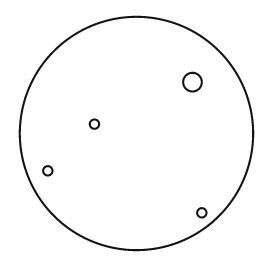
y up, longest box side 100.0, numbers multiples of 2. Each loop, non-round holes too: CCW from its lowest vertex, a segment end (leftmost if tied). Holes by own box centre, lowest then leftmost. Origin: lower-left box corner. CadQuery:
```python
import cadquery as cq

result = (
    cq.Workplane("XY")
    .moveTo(50.0, 50.0)
    .circle(50.0)
    .moveTo(78.0, 16.0)
    .circle(2.0)
    .moveTo(12.0, 34.0)
    .circle(2.0)
    .moveTo(32.0, 54.0)
    .circle(2.0)
    .moveTo(74.0, 72.0)
    .circle(4.0)
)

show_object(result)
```